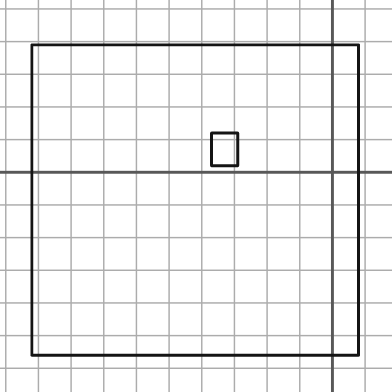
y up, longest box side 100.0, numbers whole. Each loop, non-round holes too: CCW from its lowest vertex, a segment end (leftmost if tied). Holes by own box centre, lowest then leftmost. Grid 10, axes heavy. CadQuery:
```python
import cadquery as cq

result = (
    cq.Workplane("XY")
    .moveTo(-92.0, -56.0)
    .lineTo(8.0, -56.0)
    .lineTo(8.0, 39.0)
    .lineTo(-92.0, 39.0)
    .close()
    .moveTo(-37.0, 2.0)
    .lineTo(-29.0, 2.0)
    .lineTo(-29.0, 12.0)
    .lineTo(-37.0, 12.0)
    .close()
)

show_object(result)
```